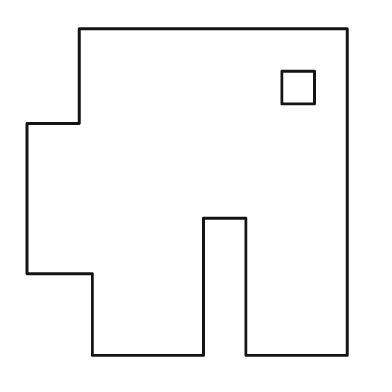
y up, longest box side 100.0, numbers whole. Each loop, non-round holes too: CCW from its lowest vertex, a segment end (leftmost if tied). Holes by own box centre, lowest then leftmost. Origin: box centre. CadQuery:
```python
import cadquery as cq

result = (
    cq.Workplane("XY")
    .moveTo(-29.0, -50.0)
    .lineTo(5.0, -50.0)
    .lineTo(5.0, -8.0)
    .lineTo(18.0, -8.0)
    .lineTo(18.0, -50.0)
    .lineTo(49.0, -50.0)
    .lineTo(49.0, 50.0)
    .lineTo(-33.0, 50.0)
    .lineTo(-33.0, 21.0)
    .lineTo(-49.0, 21.0)
    .lineTo(-49.0, -25.0)
    .lineTo(-29.0, -25.0)
    .close()
    .moveTo(29.0, 27.0)
    .lineTo(39.0, 27.0)
    .lineTo(39.0, 37.0)
    .lineTo(29.0, 37.0)
    .close()
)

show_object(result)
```